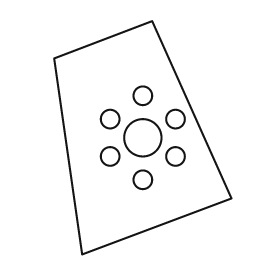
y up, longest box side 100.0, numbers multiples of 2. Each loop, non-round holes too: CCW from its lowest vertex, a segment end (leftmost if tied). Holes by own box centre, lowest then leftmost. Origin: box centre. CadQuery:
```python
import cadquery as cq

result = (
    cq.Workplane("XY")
    .moveTo(-26.0, -50.0)
    .lineTo(38.0, -26.0)
    .lineTo(4.0, 50.0)
    .lineTo(-38.0, 34.0)
    .close()
    .moveTo(0.0, -18.0)
    .circle(4.0)
    .moveTo(-14.0, -8.0)
    .circle(4.0)
    .moveTo(14.0, -8.0)
    .circle(4.0)
    .moveTo(0.0, 0.0)
    .circle(8.0)
    .moveTo(-14.0, 8.0)
    .circle(4.0)
    .moveTo(14.0, 8.0)
    .circle(4.0)
    .moveTo(0.0, 18.0)
    .circle(4.0)
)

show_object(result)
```